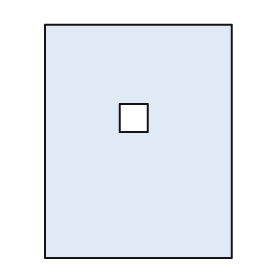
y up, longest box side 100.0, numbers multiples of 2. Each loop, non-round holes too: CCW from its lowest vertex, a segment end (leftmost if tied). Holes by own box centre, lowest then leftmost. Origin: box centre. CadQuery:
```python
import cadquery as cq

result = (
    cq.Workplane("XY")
    .moveTo(-40.0, -50.0)
    .lineTo(40.0, -50.0)
    .lineTo(40.0, 50.0)
    .lineTo(-40.0, 50.0)
    .close()
    .moveTo(-8.0, 4.0)
    .lineTo(4.0, 4.0)
    .lineTo(4.0, 16.0)
    .lineTo(-8.0, 16.0)
    .close()
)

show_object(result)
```